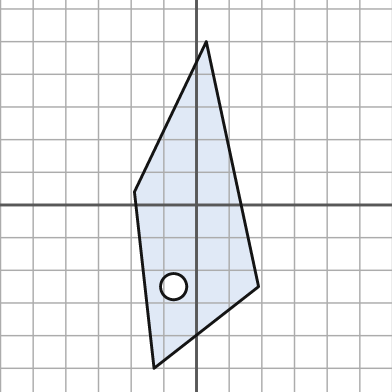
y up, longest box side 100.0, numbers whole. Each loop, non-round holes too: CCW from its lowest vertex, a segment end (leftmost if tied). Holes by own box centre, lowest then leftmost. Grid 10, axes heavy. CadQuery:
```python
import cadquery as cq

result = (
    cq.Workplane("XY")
    .moveTo(-13.0, -50.0)
    .lineTo(19.0, -25.0)
    .lineTo(3.0, 50.0)
    .lineTo(-19.0, 4.0)
    .close()
    .moveTo(-7.0, -25.0)
    .circle(4.0)
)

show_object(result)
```